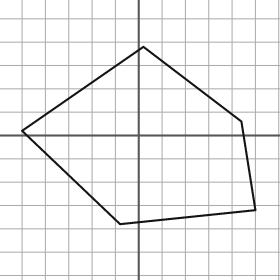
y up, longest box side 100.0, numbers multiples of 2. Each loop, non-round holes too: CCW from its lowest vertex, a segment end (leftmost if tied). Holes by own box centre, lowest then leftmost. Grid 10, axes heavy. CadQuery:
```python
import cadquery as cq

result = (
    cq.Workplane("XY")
    .moveTo(-8.0, -38.0)
    .lineTo(50.0, -32.0)
    .lineTo(44.0, 6.0)
    .lineTo(2.0, 38.0)
    .lineTo(-50.0, 2.0)
    .close()
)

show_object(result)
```